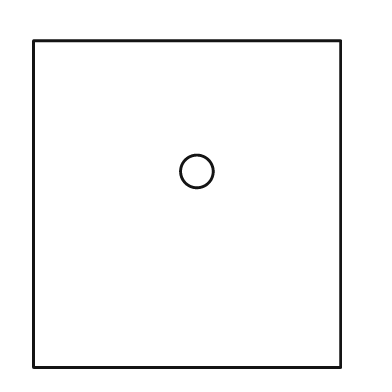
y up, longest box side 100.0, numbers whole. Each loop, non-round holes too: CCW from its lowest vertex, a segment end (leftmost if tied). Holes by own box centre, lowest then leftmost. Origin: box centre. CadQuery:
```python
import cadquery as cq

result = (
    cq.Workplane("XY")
    .moveTo(-47.0, -50.0)
    .lineTo(47.0, -50.0)
    .lineTo(47.0, 50.0)
    .lineTo(-47.0, 50.0)
    .close()
    .moveTo(3.0, 10.0)
    .circle(5.0)
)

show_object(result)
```